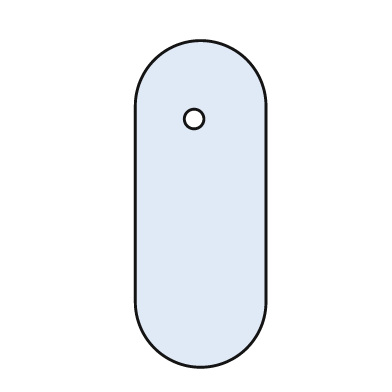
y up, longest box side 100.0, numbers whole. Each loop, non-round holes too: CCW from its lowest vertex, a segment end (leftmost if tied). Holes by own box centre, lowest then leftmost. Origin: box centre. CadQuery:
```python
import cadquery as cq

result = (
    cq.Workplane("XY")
    .moveTo(-20.0, -30.0)
    .threePointArc((0.0, -50.0), (20.0, -30.0))
    .lineTo(20.0, 30.0)
    .threePointArc((0.0, 50.0), (-20.0, 30.0))
    .close()
    .moveTo(-2.0, 26.0)
    .circle(3.0)
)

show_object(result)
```